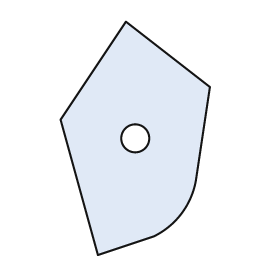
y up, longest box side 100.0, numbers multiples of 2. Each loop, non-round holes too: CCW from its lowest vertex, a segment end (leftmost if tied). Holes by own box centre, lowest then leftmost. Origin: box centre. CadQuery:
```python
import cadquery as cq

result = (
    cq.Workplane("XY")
    .moveTo(-16.0, -50.0)
    .lineTo(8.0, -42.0)
    .threePointArc((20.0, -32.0), (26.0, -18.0))
    .lineTo(32.0, 22.0)
    .lineTo(-4.0, 50.0)
    .lineTo(-32.0, 8.0)
    .close()
    .moveTo(0.0, 0.0)
    .circle(6.0)
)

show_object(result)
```